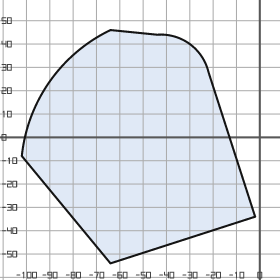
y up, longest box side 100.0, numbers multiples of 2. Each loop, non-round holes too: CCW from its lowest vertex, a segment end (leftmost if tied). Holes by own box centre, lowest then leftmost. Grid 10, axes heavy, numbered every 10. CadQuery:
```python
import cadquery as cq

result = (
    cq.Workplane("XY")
    .moveTo(-64.0, -54.0)
    .lineTo(-2.0, -34.0)
    .lineTo(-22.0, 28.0)
    .threePointArc((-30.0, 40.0), (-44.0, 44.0))
    .lineTo(-64.0, 46.0)
    .threePointArc((-90.0, 24.0), (-102.0, -8.0))
    .close()
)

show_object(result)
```